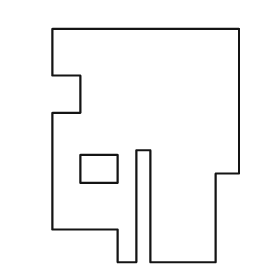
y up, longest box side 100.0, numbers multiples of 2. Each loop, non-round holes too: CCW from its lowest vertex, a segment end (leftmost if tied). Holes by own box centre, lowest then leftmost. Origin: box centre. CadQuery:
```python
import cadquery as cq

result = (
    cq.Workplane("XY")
    .moveTo(-12.0, -50.0)
    .lineTo(-4.0, -50.0)
    .lineTo(-4.0, -2.0)
    .lineTo(2.0, -2.0)
    .lineTo(2.0, -50.0)
    .lineTo(30.0, -50.0)
    .lineTo(30.0, -12.0)
    .lineTo(40.0, -12.0)
    .lineTo(40.0, 50.0)
    .lineTo(-40.0, 50.0)
    .lineTo(-40.0, 30.0)
    .lineTo(-28.0, 30.0)
    .lineTo(-28.0, 14.0)
    .lineTo(-40.0, 14.0)
    .lineTo(-40.0, -36.0)
    .lineTo(-12.0, -36.0)
    .close()
    .moveTo(-28.0, -16.0)
    .lineTo(-12.0, -16.0)
    .lineTo(-12.0, -4.0)
    .lineTo(-28.0, -4.0)
    .close()
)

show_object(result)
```